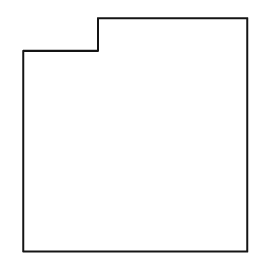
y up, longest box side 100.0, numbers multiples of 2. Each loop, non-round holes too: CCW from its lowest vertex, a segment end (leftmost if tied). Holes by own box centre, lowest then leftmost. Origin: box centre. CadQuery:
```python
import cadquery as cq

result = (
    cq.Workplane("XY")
    .moveTo(-48.0, -50.0)
    .lineTo(48.0, -50.0)
    .lineTo(48.0, 50.0)
    .lineTo(-16.0, 50.0)
    .lineTo(-16.0, 36.0)
    .lineTo(-48.0, 36.0)
    .close()
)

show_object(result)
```